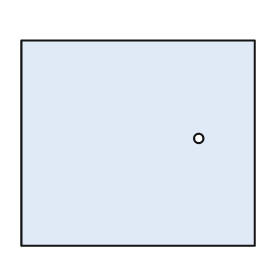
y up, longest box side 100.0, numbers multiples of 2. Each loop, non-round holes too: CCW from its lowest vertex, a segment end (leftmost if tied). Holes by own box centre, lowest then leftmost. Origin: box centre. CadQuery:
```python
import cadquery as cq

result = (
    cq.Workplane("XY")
    .moveTo(-50.0, -44.0)
    .lineTo(50.0, -44.0)
    .lineTo(50.0, 44.0)
    .lineTo(-50.0, 44.0)
    .close()
    .moveTo(26.0, 2.0)
    .circle(2.0)
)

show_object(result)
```